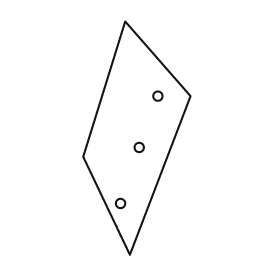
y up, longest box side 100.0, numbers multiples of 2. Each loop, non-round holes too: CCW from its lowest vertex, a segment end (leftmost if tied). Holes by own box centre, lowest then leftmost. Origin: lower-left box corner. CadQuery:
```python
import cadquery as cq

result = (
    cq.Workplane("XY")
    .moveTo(20.0, 0.0)
    .lineTo(46.0, 68.0)
    .lineTo(18.0, 100.0)
    .lineTo(0.0, 42.0)
    .close()
    .moveTo(16.0, 22.0)
    .circle(2.0)
    .moveTo(24.0, 46.0)
    .circle(2.0)
    .moveTo(32.0, 68.0)
    .circle(2.0)
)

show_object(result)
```